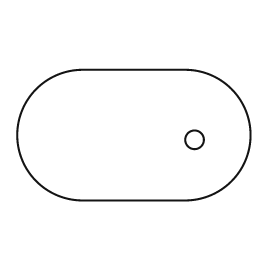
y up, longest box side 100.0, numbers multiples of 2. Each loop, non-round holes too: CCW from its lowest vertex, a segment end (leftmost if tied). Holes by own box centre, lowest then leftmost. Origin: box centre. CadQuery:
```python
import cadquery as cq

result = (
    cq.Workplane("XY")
    .moveTo(-22.0, -28.0)
    .lineTo(22.0, -28.0)
    .threePointArc((50.0, 0.0), (22.0, 28.0))
    .lineTo(-22.0, 28.0)
    .threePointArc((-50.0, 0.0), (-22.0, -28.0))
    .close()
    .moveTo(26.0, -2.0)
    .circle(4.0)
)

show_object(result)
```